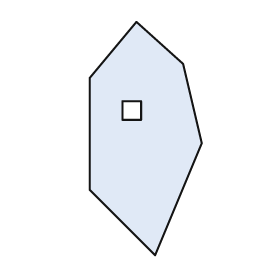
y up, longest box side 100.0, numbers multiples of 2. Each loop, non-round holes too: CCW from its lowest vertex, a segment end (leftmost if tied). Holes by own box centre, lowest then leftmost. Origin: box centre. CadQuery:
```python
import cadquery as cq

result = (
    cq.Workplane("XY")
    .moveTo(4.0, -50.0)
    .lineTo(24.0, -2.0)
    .lineTo(16.0, 32.0)
    .lineTo(-4.0, 50.0)
    .lineTo(-24.0, 26.0)
    .lineTo(-24.0, -22.0)
    .close()
    .moveTo(-10.0, 8.0)
    .lineTo(-2.0, 8.0)
    .lineTo(-2.0, 16.0)
    .lineTo(-10.0, 16.0)
    .close()
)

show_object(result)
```